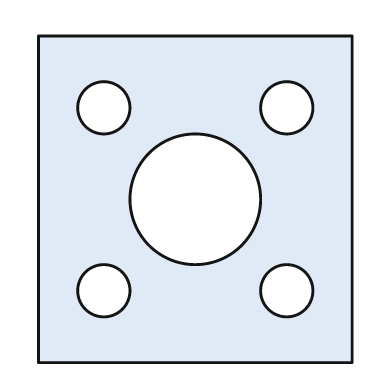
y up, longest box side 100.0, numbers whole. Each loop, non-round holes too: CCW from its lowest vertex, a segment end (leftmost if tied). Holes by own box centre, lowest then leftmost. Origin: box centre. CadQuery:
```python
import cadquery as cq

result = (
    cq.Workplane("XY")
    .moveTo(-48.0, -50.0)
    .lineTo(48.0, -50.0)
    .lineTo(48.0, 50.0)
    .lineTo(-48.0, 50.0)
    .close()
    .moveTo(-28.0, -28.0)
    .circle(8.0)
    .moveTo(28.0, -28.0)
    .circle(8.0)
    .moveTo(0.0, 0.0)
    .circle(20.0)
    .moveTo(-28.0, 28.0)
    .circle(8.0)
    .moveTo(28.0, 28.0)
    .circle(8.0)
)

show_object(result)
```